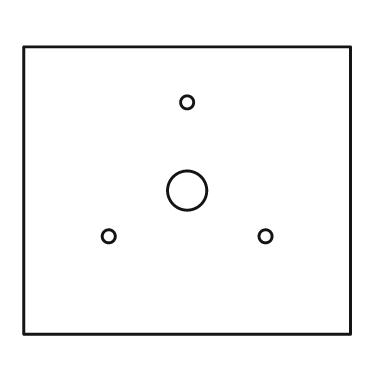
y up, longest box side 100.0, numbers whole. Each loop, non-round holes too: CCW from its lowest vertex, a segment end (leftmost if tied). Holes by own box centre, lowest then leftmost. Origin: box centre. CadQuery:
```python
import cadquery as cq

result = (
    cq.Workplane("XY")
    .moveTo(-50.0, -44.0)
    .lineTo(50.0, -44.0)
    .lineTo(50.0, 44.0)
    .lineTo(-50.0, 44.0)
    .close()
    .moveTo(-24.0, -14.0)
    .circle(2.0)
    .moveTo(24.0, -14.0)
    .circle(2.0)
    .moveTo(0.0, 0.0)
    .circle(6.0)
    .moveTo(0.0, 27.0)
    .circle(2.0)
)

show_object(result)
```